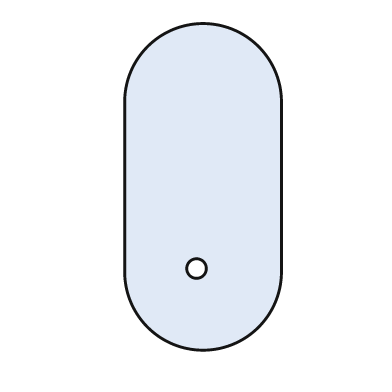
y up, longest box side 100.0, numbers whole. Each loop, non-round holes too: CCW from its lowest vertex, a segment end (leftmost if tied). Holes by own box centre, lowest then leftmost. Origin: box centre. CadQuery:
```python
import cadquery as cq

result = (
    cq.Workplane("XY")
    .moveTo(-24.0, -26.0)
    .threePointArc((0.0, -50.0), (24.0, -26.0))
    .lineTo(24.0, 26.0)
    .threePointArc((0.0, 50.0), (-24.0, 26.0))
    .close()
    .moveTo(-2.0, -25.0)
    .circle(3.0)
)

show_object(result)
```